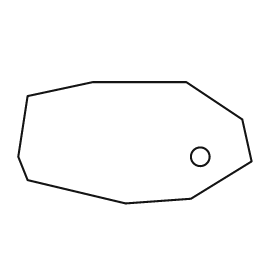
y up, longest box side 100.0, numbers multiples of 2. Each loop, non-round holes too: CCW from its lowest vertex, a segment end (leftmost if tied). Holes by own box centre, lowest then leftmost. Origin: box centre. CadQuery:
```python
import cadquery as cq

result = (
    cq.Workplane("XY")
    .moveTo(-4.0, -26.0)
    .lineTo(24.0, -24.0)
    .lineTo(50.0, -8.0)
    .lineTo(46.0, 10.0)
    .lineTo(22.0, 26.0)
    .lineTo(-18.0, 26.0)
    .lineTo(-46.0, 20.0)
    .lineTo(-50.0, -6.0)
    .lineTo(-46.0, -16.0)
    .close()
    .moveTo(28.0, -6.0)
    .circle(4.0)
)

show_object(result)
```